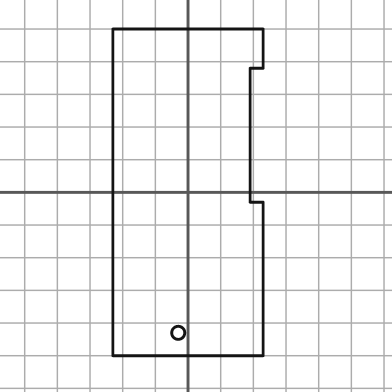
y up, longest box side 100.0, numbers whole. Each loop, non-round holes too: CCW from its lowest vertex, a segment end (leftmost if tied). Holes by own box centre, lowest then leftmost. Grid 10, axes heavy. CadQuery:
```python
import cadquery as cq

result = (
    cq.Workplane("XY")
    .moveTo(-23.0, -50.0)
    .lineTo(23.0, -50.0)
    .lineTo(23.0, -3.0)
    .lineTo(19.0, -3.0)
    .lineTo(19.0, 38.0)
    .lineTo(23.0, 38.0)
    .lineTo(23.0, 50.0)
    .lineTo(-23.0, 50.0)
    .close()
    .moveTo(-3.0, -43.0)
    .circle(2.0)
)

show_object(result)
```